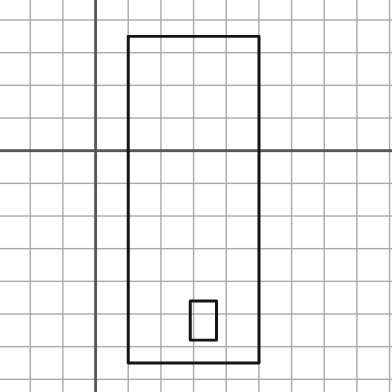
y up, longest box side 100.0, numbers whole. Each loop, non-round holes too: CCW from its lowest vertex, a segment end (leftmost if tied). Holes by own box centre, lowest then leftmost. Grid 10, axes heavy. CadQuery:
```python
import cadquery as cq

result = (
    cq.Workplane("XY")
    .moveTo(10.0, -65.0)
    .lineTo(50.0, -65.0)
    .lineTo(50.0, 35.0)
    .lineTo(10.0, 35.0)
    .close()
    .moveTo(29.0, -58.0)
    .lineTo(37.0, -58.0)
    .lineTo(37.0, -46.0)
    .lineTo(29.0, -46.0)
    .close()
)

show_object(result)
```